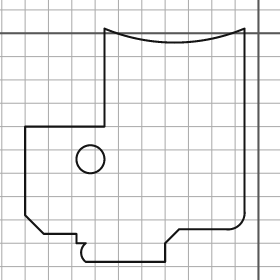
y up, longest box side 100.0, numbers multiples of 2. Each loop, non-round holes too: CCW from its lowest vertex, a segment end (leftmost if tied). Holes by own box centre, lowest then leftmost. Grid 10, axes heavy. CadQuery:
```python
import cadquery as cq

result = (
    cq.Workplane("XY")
    .moveTo(-74.0, -98.0)
    .lineTo(-40.0, -98.0)
    .lineTo(-40.0, -90.0)
    .lineTo(-34.0, -84.0)
    .lineTo(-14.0, -84.0)
    .threePointArc((-8.0, -82.0), (-6.0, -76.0))
    .lineTo(-6.0, 2.0)
    .threePointArc((-36.0, -4.0), (-66.0, 2.0))
    .lineTo(-66.0, -40.0)
    .lineTo(-100.0, -40.0)
    .lineTo(-100.0, -78.0)
    .lineTo(-92.0, -86.0)
    .lineTo(-78.0, -86.0)
    .lineTo(-78.0, -90.0)
    .lineTo(-74.0, -90.0)
    .threePointArc((-76.0, -94.0), (-74.0, -98.0))
    .close()
    .moveTo(-72.0, -54.0)
    .circle(6.0)
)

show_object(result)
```